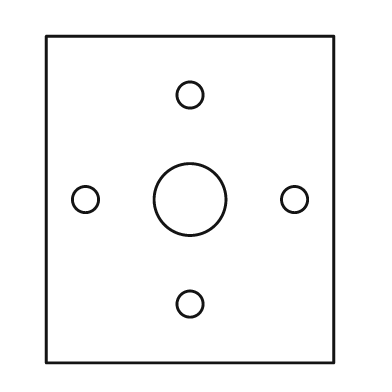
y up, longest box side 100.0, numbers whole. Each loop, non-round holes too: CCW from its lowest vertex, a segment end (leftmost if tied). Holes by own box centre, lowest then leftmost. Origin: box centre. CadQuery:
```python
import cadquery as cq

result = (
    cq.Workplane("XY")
    .moveTo(-44.0, -50.0)
    .lineTo(44.0, -50.0)
    .lineTo(44.0, 50.0)
    .lineTo(-44.0, 50.0)
    .close()
    .moveTo(0.0, -32.0)
    .circle(4.0)
    .moveTo(-32.0, 0.0)
    .circle(4.0)
    .moveTo(0.0, 0.0)
    .circle(11.0)
    .moveTo(32.0, 0.0)
    .circle(4.0)
    .moveTo(0.0, 32.0)
    .circle(4.0)
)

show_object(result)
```